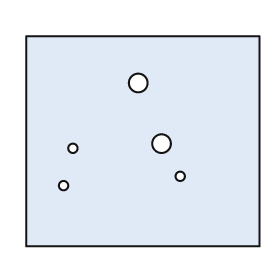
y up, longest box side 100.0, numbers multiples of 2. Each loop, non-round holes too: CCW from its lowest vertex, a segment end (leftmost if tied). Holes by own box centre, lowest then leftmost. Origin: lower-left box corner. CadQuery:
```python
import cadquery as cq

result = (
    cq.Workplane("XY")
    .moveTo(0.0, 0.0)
    .lineTo(100.0, 0.0)
    .lineTo(100.0, 90.0)
    .lineTo(0.0, 90.0)
    .close()
    .moveTo(16.0, 26.0)
    .circle(2.0)
    .moveTo(66.0, 30.0)
    .circle(2.0)
    .moveTo(20.0, 42.0)
    .circle(2.0)
    .moveTo(58.0, 44.0)
    .circle(4.0)
    .moveTo(48.0, 70.0)
    .circle(4.0)
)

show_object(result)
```